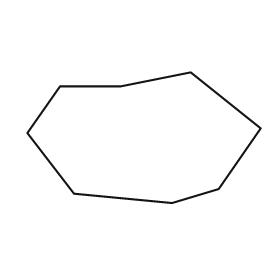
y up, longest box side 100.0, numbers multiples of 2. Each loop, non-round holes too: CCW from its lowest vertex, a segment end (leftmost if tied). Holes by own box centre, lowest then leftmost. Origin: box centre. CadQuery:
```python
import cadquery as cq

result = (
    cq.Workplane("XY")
    .moveTo(12.0, -28.0)
    .lineTo(32.0, -22.0)
    .lineTo(50.0, 4.0)
    .lineTo(20.0, 28.0)
    .lineTo(-10.0, 22.0)
    .lineTo(-36.0, 22.0)
    .lineTo(-50.0, 2.0)
    .lineTo(-30.0, -24.0)
    .close()
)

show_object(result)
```